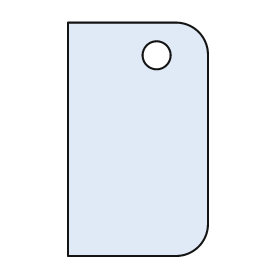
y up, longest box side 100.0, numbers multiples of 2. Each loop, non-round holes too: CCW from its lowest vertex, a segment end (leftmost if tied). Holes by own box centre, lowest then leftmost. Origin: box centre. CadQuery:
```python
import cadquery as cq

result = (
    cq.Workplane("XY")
    .moveTo(-30.0, -50.0)
    .lineTo(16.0, -50.0)
    .threePointArc((26.0, -46.0), (30.0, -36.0))
    .lineTo(30.0, 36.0)
    .threePointArc((26.0, 46.0), (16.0, 50.0))
    .lineTo(-30.0, 50.0)
    .close()
    .moveTo(8.0, 36.0)
    .circle(6.0)
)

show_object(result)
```